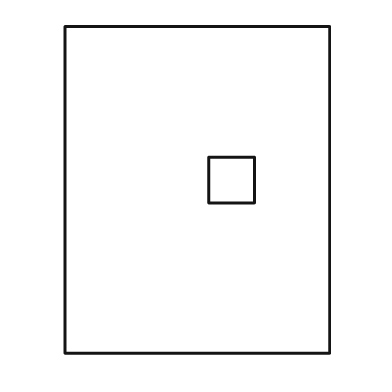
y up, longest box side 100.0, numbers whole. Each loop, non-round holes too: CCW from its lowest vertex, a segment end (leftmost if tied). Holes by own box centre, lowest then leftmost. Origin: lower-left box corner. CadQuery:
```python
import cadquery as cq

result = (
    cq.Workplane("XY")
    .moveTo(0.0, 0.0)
    .lineTo(81.0, 0.0)
    .lineTo(81.0, 100.0)
    .lineTo(0.0, 100.0)
    .close()
    .moveTo(44.0, 46.0)
    .lineTo(58.0, 46.0)
    .lineTo(58.0, 60.0)
    .lineTo(44.0, 60.0)
    .close()
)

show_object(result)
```